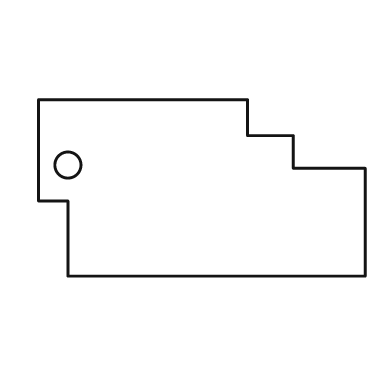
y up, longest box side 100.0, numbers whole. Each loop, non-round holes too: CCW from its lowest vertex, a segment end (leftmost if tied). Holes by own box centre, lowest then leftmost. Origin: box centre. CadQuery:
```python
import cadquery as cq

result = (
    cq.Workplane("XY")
    .moveTo(-41.0, -27.0)
    .lineTo(50.0, -27.0)
    .lineTo(50.0, 6.0)
    .lineTo(28.0, 6.0)
    .lineTo(28.0, 16.0)
    .lineTo(14.0, 16.0)
    .lineTo(14.0, 27.0)
    .lineTo(-50.0, 27.0)
    .lineTo(-50.0, -4.0)
    .lineTo(-41.0, -4.0)
    .close()
    .moveTo(-41.0, 7.0)
    .circle(4.0)
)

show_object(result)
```